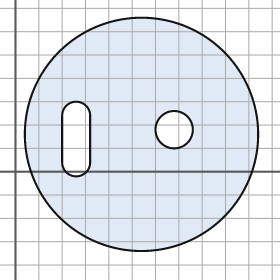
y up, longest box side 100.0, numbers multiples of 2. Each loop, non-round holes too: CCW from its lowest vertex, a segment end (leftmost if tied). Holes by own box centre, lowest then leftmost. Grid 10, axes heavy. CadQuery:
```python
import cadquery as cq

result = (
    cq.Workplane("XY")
    .moveTo(54.0, 16.0)
    .circle(50.0)
    .moveTo(20.0, 4.0)
    .threePointArc((26.0, -2.0), (32.0, 4.0))
    .lineTo(32.0, 24.0)
    .threePointArc((26.0, 30.0), (20.0, 24.0))
    .close()
    .moveTo(68.0, 18.0)
    .circle(8.0)
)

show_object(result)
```